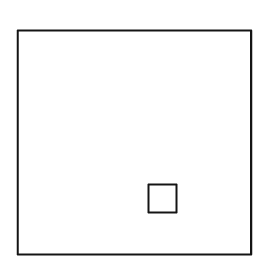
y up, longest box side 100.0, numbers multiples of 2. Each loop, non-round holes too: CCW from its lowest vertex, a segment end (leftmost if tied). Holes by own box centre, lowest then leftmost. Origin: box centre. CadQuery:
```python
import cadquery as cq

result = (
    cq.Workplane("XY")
    .moveTo(-50.0, -48.0)
    .lineTo(50.0, -48.0)
    .lineTo(50.0, 48.0)
    .lineTo(-50.0, 48.0)
    .close()
    .moveTo(6.0, -30.0)
    .lineTo(18.0, -30.0)
    .lineTo(18.0, -18.0)
    .lineTo(6.0, -18.0)
    .close()
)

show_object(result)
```